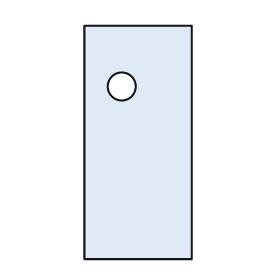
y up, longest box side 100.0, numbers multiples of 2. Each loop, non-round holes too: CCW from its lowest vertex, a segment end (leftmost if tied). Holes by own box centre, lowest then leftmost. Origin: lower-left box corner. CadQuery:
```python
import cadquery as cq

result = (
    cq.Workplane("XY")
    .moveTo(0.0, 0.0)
    .lineTo(46.0, 0.0)
    .lineTo(46.0, 100.0)
    .lineTo(0.0, 100.0)
    .close()
    .moveTo(16.0, 74.0)
    .circle(6.0)
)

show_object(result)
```